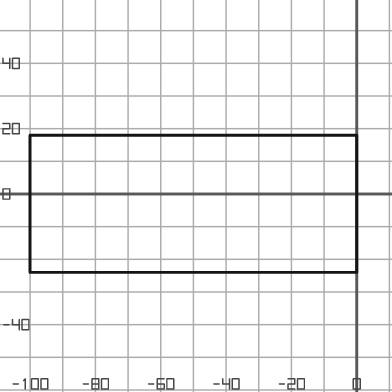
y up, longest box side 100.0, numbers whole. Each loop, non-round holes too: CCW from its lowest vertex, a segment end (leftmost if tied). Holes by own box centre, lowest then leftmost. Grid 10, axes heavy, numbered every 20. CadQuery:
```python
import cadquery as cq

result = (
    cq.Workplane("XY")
    .moveTo(-100.0, -24.0)
    .lineTo(0.0, -24.0)
    .lineTo(0.0, 18.0)
    .lineTo(-100.0, 18.0)
    .close()
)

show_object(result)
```